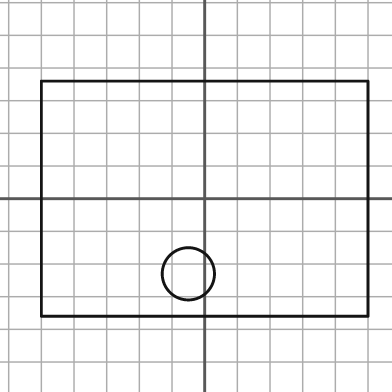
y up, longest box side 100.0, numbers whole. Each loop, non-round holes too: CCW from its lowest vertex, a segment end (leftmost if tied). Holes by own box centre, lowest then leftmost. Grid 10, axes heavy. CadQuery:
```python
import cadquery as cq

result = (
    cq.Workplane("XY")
    .moveTo(-50.0, -36.0)
    .lineTo(50.0, -36.0)
    .lineTo(50.0, 36.0)
    .lineTo(-50.0, 36.0)
    .close()
    .moveTo(-5.0, -23.0)
    .circle(8.0)
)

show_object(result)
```